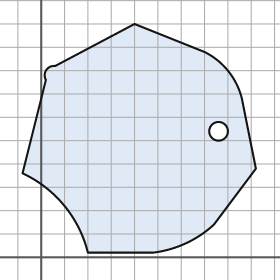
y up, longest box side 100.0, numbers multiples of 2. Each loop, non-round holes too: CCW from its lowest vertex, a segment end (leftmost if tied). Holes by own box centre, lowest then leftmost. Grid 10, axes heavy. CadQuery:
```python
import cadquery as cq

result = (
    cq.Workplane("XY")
    .moveTo(20.0, 2.0)
    .lineTo(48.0, 2.0)
    .threePointArc((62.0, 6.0), (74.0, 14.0))
    .lineTo(92.0, 38.0)
    .lineTo(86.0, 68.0)
    .threePointArc((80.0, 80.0), (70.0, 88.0))
    .lineTo(40.0, 100.0)
    .lineTo(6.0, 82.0)
    .threePointArc((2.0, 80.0), (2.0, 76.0))
    .lineTo(-8.0, 36.0)
    .threePointArc((10.0, 22.0), (20.0, 2.0))
    .close()
    .moveTo(76.0, 54.0)
    .circle(4.0)
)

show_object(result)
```